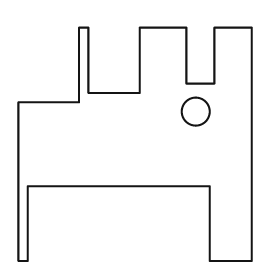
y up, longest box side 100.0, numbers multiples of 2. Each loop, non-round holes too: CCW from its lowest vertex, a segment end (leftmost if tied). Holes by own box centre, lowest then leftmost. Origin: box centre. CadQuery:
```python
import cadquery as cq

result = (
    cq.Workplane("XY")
    .moveTo(-50.0, -50.0)
    .lineTo(-46.0, -50.0)
    .lineTo(-46.0, -18.0)
    .lineTo(32.0, -18.0)
    .lineTo(32.0, -50.0)
    .lineTo(50.0, -50.0)
    .lineTo(50.0, 50.0)
    .lineTo(34.0, 50.0)
    .lineTo(34.0, 26.0)
    .lineTo(22.0, 26.0)
    .lineTo(22.0, 50.0)
    .lineTo(2.0, 50.0)
    .lineTo(2.0, 22.0)
    .lineTo(-20.0, 22.0)
    .lineTo(-20.0, 50.0)
    .lineTo(-24.0, 50.0)
    .lineTo(-24.0, 18.0)
    .lineTo(-50.0, 18.0)
    .close()
    .moveTo(26.0, 14.0)
    .circle(6.0)
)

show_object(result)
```